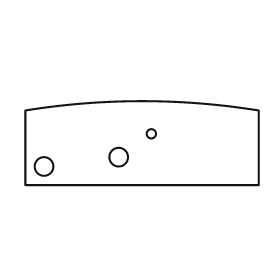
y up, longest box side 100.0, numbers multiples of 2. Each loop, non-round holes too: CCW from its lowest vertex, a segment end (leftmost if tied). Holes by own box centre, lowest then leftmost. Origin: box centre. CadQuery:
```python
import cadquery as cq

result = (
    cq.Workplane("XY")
    .moveTo(-50.0, -18.0)
    .lineTo(50.0, -18.0)
    .lineTo(50.0, 14.0)
    .threePointArc((0.0, 18.0), (-50.0, 14.0))
    .close()
    .moveTo(-42.0, -10.0)
    .circle(4.0)
    .moveTo(-10.0, -6.0)
    .circle(4.0)
    .moveTo(4.0, 4.0)
    .circle(2.0)
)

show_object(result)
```